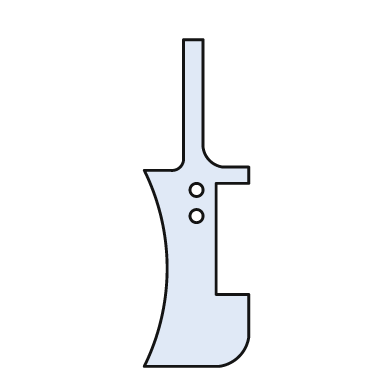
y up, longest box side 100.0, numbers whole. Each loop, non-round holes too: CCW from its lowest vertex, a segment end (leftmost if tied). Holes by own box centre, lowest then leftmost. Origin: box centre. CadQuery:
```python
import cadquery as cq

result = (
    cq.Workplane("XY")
    .moveTo(-16.0, -50.0)
    .lineTo(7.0, -50.0)
    .threePointArc((13.0, -47.0), (16.0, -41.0))
    .lineTo(16.0, -28.0)
    .lineTo(6.0, -28.0)
    .lineTo(6.0, 6.0)
    .lineTo(16.0, 6.0)
    .lineTo(16.0, 11.0)
    .lineTo(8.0, 11.0)
    .threePointArc((4.0, 13.0), (2.0, 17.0))
    .lineTo(2.0, 50.0)
    .lineTo(-4.0, 50.0)
    .lineTo(-4.0, 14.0)
    .threePointArc((-5.0, 11.0), (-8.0, 10.0))
    .lineTo(-16.0, 10.0)
    .threePointArc((-9.0, -20.0), (-16.0, -50.0))
    .close()
    .moveTo(0.0, -4.0)
    .circle(2.0)
    .moveTo(0.0, 4.0)
    .circle(2.0)
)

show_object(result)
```